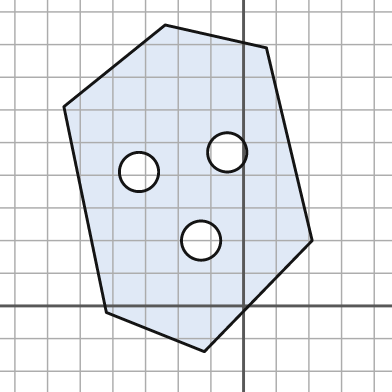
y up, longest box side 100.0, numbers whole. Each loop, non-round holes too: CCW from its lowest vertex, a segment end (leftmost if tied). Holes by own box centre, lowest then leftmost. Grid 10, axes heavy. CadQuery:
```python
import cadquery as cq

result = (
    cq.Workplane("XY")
    .moveTo(-12.0, -14.0)
    .lineTo(21.0, 20.0)
    .lineTo(7.0, 79.0)
    .lineTo(-24.0, 86.0)
    .lineTo(-55.0, 61.0)
    .lineTo(-42.0, -2.0)
    .close()
    .moveTo(-13.0, 20.0)
    .circle(6.0)
    .moveTo(-32.0, 41.0)
    .circle(6.0)
    .moveTo(-5.0, 47.0)
    .circle(6.0)
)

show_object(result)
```